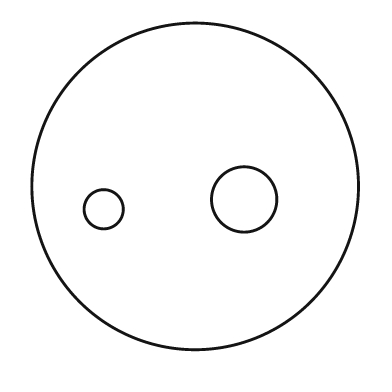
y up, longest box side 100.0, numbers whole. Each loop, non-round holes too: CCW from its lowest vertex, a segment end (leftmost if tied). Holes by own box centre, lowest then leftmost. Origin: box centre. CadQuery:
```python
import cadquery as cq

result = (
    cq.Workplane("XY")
    .moveTo(0.0, 0.0)
    .circle(50.0)
    .moveTo(-28.0, -7.0)
    .circle(6.0)
    .moveTo(15.0, -4.0)
    .circle(10.0)
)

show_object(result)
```